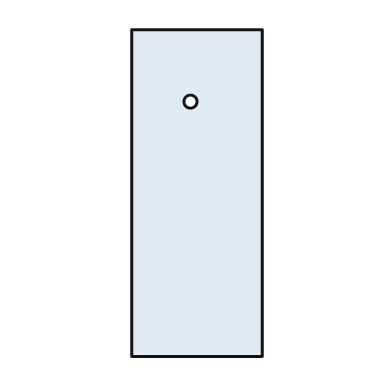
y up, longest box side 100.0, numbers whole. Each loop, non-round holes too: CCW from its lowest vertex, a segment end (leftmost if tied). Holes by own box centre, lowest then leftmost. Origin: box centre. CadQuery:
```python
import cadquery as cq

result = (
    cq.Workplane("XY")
    .moveTo(-20.0, -50.0)
    .lineTo(20.0, -50.0)
    .lineTo(20.0, 50.0)
    .lineTo(-20.0, 50.0)
    .close()
    .moveTo(-2.0, 28.0)
    .circle(2.0)
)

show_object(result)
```